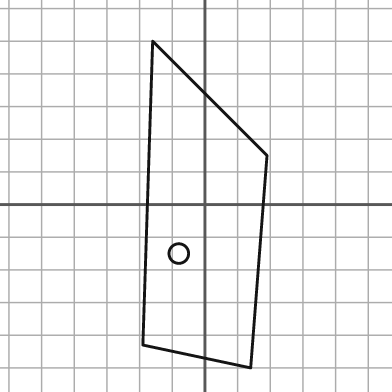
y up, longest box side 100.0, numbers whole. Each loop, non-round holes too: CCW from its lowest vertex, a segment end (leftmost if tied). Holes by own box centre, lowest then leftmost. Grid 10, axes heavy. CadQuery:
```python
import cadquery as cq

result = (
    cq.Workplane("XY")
    .moveTo(14.0, -50.0)
    .lineTo(19.0, 15.0)
    .lineTo(-16.0, 50.0)
    .lineTo(-19.0, -43.0)
    .close()
    .moveTo(-8.0, -15.0)
    .circle(3.0)
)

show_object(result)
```